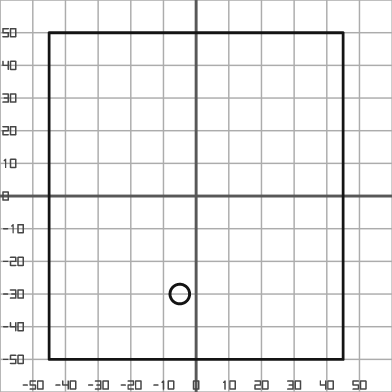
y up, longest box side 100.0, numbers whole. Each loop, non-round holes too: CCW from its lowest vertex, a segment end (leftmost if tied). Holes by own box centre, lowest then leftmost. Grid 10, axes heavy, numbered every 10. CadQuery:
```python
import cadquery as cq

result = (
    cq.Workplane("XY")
    .moveTo(-45.0, -50.0)
    .lineTo(45.0, -50.0)
    .lineTo(45.0, 50.0)
    .lineTo(-45.0, 50.0)
    .close()
    .moveTo(-5.0, -30.0)
    .circle(3.0)
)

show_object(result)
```